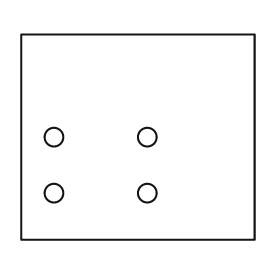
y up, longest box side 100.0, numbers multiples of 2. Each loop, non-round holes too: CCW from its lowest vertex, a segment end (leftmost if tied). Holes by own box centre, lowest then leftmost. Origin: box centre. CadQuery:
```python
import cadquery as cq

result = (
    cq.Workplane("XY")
    .moveTo(-50.0, -44.0)
    .lineTo(50.0, -44.0)
    .lineTo(50.0, 44.0)
    .lineTo(-50.0, 44.0)
    .close()
    .moveTo(-36.0, -24.0)
    .circle(4.0)
    .moveTo(4.0, -24.0)
    .circle(4.0)
    .moveTo(-36.0, 0.0)
    .circle(4.0)
    .moveTo(4.0, 0.0)
    .circle(4.0)
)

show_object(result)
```